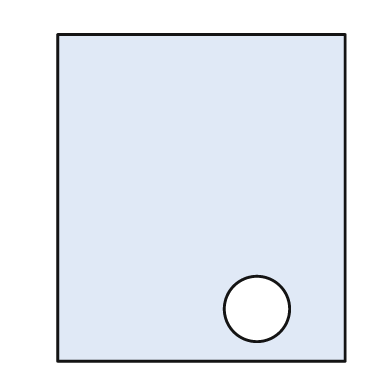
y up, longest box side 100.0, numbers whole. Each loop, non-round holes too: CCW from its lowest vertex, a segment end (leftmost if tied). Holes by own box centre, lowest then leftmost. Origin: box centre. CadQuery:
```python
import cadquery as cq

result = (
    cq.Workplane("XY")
    .moveTo(-44.0, -50.0)
    .lineTo(44.0, -50.0)
    .lineTo(44.0, 50.0)
    .lineTo(-44.0, 50.0)
    .close()
    .moveTo(17.0, -34.0)
    .circle(10.0)
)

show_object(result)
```